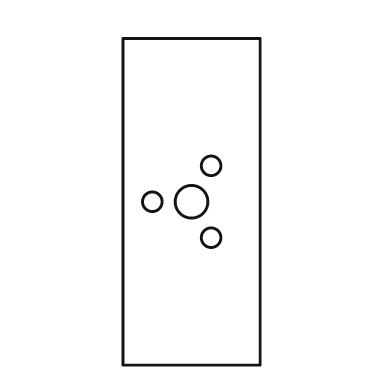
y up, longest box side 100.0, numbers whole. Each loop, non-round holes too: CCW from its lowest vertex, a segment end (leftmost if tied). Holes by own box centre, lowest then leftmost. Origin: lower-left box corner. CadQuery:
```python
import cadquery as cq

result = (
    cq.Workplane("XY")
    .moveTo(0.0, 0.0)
    .lineTo(42.0, 0.0)
    .lineTo(42.0, 100.0)
    .lineTo(0.0, 100.0)
    .close()
    .moveTo(27.0, 39.0)
    .circle(3.0)
    .moveTo(9.0, 50.0)
    .circle(3.0)
    .moveTo(21.0, 50.0)
    .circle(5.0)
    .moveTo(27.0, 61.0)
    .circle(3.0)
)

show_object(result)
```